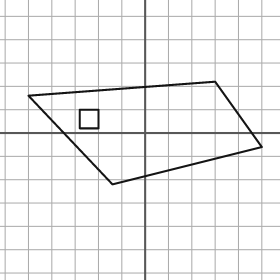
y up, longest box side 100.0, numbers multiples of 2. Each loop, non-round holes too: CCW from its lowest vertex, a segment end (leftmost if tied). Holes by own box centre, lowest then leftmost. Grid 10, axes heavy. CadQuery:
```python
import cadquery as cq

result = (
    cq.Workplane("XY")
    .moveTo(-14.0, -22.0)
    .lineTo(50.0, -6.0)
    .lineTo(30.0, 22.0)
    .lineTo(-50.0, 16.0)
    .close()
    .moveTo(-28.0, 2.0)
    .lineTo(-20.0, 2.0)
    .lineTo(-20.0, 10.0)
    .lineTo(-28.0, 10.0)
    .close()
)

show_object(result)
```